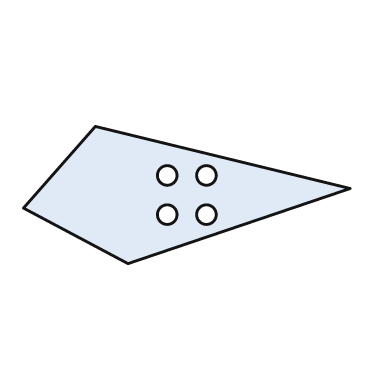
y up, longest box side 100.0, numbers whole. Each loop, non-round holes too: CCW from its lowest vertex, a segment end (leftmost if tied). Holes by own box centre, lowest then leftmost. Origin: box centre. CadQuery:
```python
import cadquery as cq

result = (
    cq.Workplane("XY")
    .moveTo(-18.0, -21.0)
    .lineTo(50.0, 2.0)
    .lineTo(-28.0, 21.0)
    .lineTo(-50.0, -4.0)
    .close()
    .moveTo(-6.0, -6.0)
    .circle(3.0)
    .moveTo(6.0, -6.0)
    .circle(3.0)
    .moveTo(-6.0, 6.0)
    .circle(3.0)
    .moveTo(6.0, 6.0)
    .circle(3.0)
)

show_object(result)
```